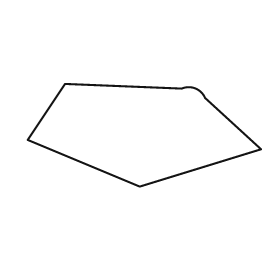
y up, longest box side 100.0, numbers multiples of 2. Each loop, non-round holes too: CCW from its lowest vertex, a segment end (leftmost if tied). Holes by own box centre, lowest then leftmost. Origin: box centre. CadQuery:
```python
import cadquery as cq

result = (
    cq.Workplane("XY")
    .moveTo(-2.0, -22.0)
    .lineTo(50.0, -6.0)
    .lineTo(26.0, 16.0)
    .threePointArc((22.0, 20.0), (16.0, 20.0))
    .lineTo(-34.0, 22.0)
    .lineTo(-50.0, -2.0)
    .close()
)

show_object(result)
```